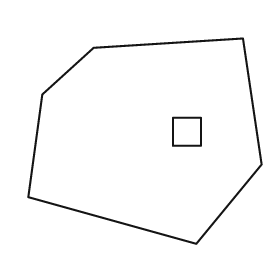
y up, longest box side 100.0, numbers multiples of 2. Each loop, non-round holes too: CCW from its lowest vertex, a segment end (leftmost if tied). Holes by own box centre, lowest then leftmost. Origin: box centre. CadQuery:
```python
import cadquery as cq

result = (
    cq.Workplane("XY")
    .moveTo(22.0, -44.0)
    .lineTo(50.0, -10.0)
    .lineTo(42.0, 44.0)
    .lineTo(-22.0, 40.0)
    .lineTo(-44.0, 20.0)
    .lineTo(-50.0, -24.0)
    .close()
    .moveTo(12.0, -2.0)
    .lineTo(24.0, -2.0)
    .lineTo(24.0, 10.0)
    .lineTo(12.0, 10.0)
    .close()
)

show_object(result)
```